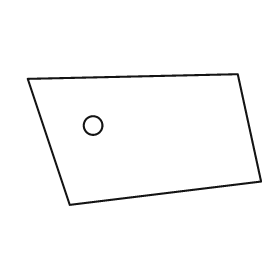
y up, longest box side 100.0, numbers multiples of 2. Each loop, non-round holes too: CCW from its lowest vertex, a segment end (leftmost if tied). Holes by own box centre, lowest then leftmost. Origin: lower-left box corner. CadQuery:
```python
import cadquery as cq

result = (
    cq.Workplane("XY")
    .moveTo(18.0, 0.0)
    .lineTo(100.0, 10.0)
    .lineTo(90.0, 56.0)
    .lineTo(0.0, 54.0)
    .close()
    .moveTo(28.0, 34.0)
    .circle(4.0)
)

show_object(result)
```